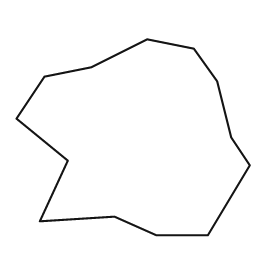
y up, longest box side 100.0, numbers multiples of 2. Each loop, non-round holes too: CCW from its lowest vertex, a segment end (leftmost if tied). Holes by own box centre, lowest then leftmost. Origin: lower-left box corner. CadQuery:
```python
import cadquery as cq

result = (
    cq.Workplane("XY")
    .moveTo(60.0, 0.0)
    .lineTo(82.0, 0.0)
    .lineTo(100.0, 30.0)
    .lineTo(92.0, 42.0)
    .lineTo(86.0, 66.0)
    .lineTo(76.0, 80.0)
    .lineTo(56.0, 84.0)
    .lineTo(32.0, 72.0)
    .lineTo(12.0, 68.0)
    .lineTo(0.0, 50.0)
    .lineTo(22.0, 32.0)
    .lineTo(10.0, 6.0)
    .lineTo(42.0, 8.0)
    .close()
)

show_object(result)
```